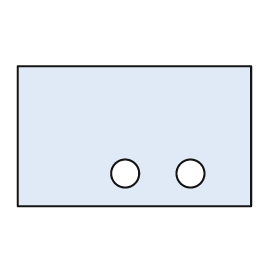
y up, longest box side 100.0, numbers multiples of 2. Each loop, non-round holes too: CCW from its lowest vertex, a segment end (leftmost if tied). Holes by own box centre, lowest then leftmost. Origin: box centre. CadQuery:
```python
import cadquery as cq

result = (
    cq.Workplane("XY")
    .moveTo(-50.0, -30.0)
    .lineTo(50.0, -30.0)
    .lineTo(50.0, 30.0)
    .lineTo(-50.0, 30.0)
    .close()
    .moveTo(-4.0, -16.0)
    .circle(6.0)
    .moveTo(24.0, -16.0)
    .circle(6.0)
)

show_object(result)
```